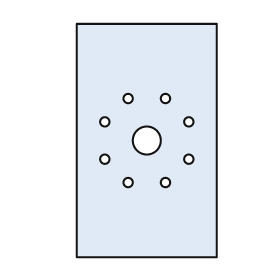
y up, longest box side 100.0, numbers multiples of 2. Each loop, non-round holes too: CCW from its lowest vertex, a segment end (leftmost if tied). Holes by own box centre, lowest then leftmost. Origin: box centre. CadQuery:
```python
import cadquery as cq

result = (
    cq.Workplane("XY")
    .moveTo(-30.0, -50.0)
    .lineTo(30.0, -50.0)
    .lineTo(30.0, 50.0)
    .lineTo(-30.0, 50.0)
    .close()
    .moveTo(-8.0, -18.0)
    .circle(2.0)
    .moveTo(8.0, -18.0)
    .circle(2.0)
    .moveTo(-18.0, -8.0)
    .circle(2.0)
    .moveTo(18.0, -8.0)
    .circle(2.0)
    .moveTo(0.0, 0.0)
    .circle(6.0)
    .moveTo(-18.0, 8.0)
    .circle(2.0)
    .moveTo(18.0, 8.0)
    .circle(2.0)
    .moveTo(-8.0, 18.0)
    .circle(2.0)
    .moveTo(8.0, 18.0)
    .circle(2.0)
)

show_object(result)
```